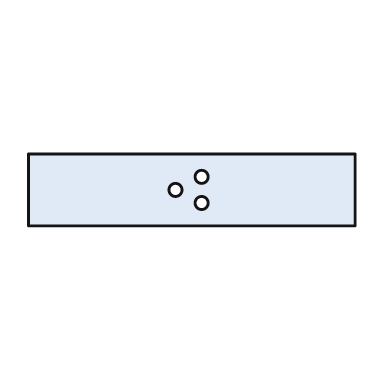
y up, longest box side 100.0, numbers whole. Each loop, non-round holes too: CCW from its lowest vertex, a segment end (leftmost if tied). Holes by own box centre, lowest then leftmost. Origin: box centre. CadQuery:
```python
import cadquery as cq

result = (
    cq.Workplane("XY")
    .moveTo(-50.0, -11.0)
    .lineTo(50.0, -11.0)
    .lineTo(50.0, 11.0)
    .lineTo(-50.0, 11.0)
    .close()
    .moveTo(3.0, -4.0)
    .circle(2.0)
    .moveTo(-5.0, 0.0)
    .circle(2.0)
    .moveTo(3.0, 4.0)
    .circle(2.0)
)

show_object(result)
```